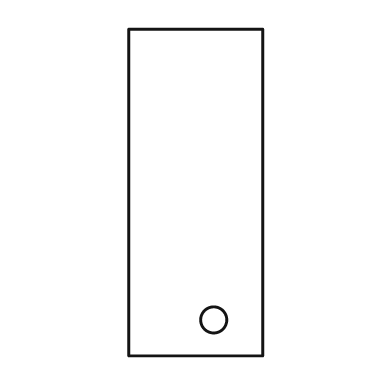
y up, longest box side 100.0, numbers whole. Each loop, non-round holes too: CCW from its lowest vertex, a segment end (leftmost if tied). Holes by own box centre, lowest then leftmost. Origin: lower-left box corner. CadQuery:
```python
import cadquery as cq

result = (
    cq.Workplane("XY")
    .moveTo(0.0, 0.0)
    .lineTo(41.0, 0.0)
    .lineTo(41.0, 100.0)
    .lineTo(0.0, 100.0)
    .close()
    .moveTo(26.0, 11.0)
    .circle(4.0)
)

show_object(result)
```